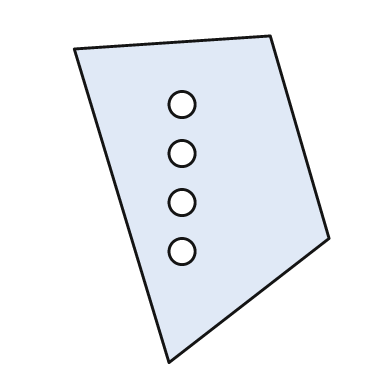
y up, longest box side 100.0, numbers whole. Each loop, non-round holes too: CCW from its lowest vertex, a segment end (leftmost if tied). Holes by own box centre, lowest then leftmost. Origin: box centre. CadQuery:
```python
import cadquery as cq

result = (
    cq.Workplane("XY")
    .moveTo(-10.0, -50.0)
    .lineTo(39.0, -12.0)
    .lineTo(21.0, 50.0)
    .lineTo(-39.0, 46.0)
    .close()
    .moveTo(-6.0, -16.0)
    .circle(4.0)
    .moveTo(-6.0, -1.0)
    .circle(4.0)
    .moveTo(-6.0, 14.0)
    .circle(4.0)
    .moveTo(-6.0, 29.0)
    .circle(4.0)
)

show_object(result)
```